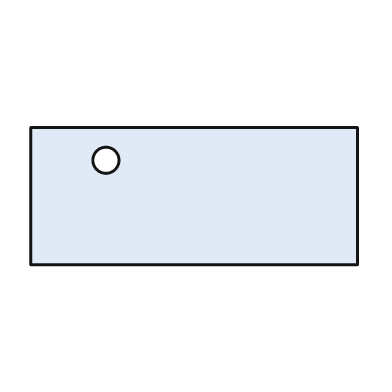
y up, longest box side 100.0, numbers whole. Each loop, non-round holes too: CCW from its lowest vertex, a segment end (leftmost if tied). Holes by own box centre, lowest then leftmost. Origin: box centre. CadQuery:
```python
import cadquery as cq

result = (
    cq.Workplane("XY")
    .moveTo(-50.0, -21.0)
    .lineTo(50.0, -21.0)
    .lineTo(50.0, 21.0)
    .lineTo(-50.0, 21.0)
    .close()
    .moveTo(-27.0, 11.0)
    .circle(4.0)
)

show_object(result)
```